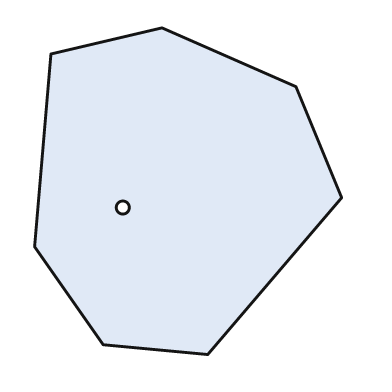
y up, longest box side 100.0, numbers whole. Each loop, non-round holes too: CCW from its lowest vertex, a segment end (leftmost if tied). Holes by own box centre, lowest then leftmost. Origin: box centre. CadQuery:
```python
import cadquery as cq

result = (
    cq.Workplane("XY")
    .moveTo(6.0, -50.0)
    .lineTo(47.0, -2.0)
    .lineTo(33.0, 32.0)
    .lineTo(-8.0, 50.0)
    .lineTo(-42.0, 42.0)
    .lineTo(-47.0, -17.0)
    .lineTo(-26.0, -47.0)
    .close()
    .moveTo(-20.0, -5.0)
    .circle(2.0)
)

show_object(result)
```